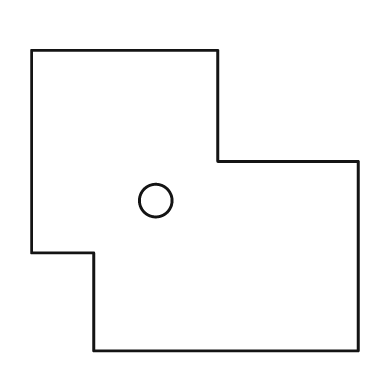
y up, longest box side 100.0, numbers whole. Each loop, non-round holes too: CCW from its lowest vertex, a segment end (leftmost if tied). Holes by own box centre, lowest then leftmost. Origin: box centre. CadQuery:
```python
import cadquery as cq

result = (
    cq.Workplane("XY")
    .moveTo(-31.0, -46.0)
    .lineTo(50.0, -46.0)
    .lineTo(50.0, 12.0)
    .lineTo(7.0, 12.0)
    .lineTo(7.0, 46.0)
    .lineTo(-50.0, 46.0)
    .lineTo(-50.0, -16.0)
    .lineTo(-31.0, -16.0)
    .close()
    .moveTo(-12.0, 0.0)
    .circle(5.0)
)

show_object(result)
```